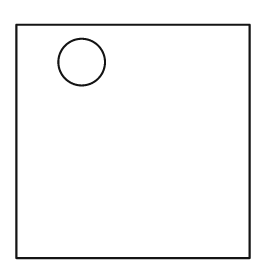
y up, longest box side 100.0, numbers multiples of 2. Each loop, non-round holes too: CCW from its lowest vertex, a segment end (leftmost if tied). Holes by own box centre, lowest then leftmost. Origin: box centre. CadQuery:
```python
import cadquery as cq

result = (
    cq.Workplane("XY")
    .moveTo(-50.0, -50.0)
    .lineTo(50.0, -50.0)
    .lineTo(50.0, 50.0)
    .lineTo(-50.0, 50.0)
    .close()
    .moveTo(-22.0, 34.0)
    .circle(10.0)
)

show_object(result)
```